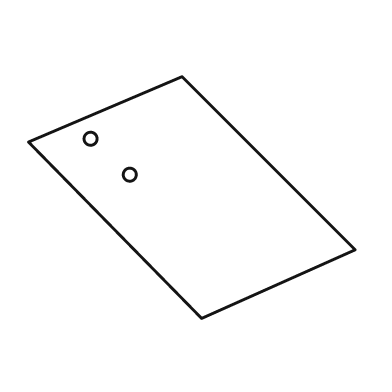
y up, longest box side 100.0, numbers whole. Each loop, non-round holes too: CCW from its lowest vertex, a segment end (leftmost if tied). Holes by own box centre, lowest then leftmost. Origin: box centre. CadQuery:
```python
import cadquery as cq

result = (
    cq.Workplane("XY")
    .moveTo(3.0, -37.0)
    .lineTo(50.0, -16.0)
    .lineTo(-3.0, 37.0)
    .lineTo(-50.0, 17.0)
    .close()
    .moveTo(-19.0, 7.0)
    .circle(2.0)
    .moveTo(-31.0, 18.0)
    .circle(2.0)
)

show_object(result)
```